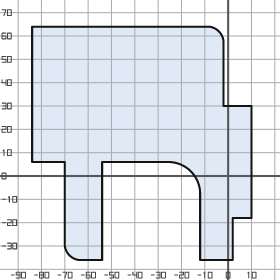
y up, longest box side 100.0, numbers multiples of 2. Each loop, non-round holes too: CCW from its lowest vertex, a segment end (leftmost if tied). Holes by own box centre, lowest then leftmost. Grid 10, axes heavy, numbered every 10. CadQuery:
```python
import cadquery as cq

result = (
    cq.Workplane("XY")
    .moveTo(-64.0, -36.0)
    .lineTo(-54.0, -36.0)
    .lineTo(-54.0, 6.0)
    .lineTo(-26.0, 6.0)
    .threePointArc((-16.0, 2.0), (-12.0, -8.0))
    .lineTo(-12.0, -36.0)
    .lineTo(2.0, -36.0)
    .lineTo(2.0, -18.0)
    .lineTo(10.0, -18.0)
    .lineTo(10.0, 30.0)
    .lineTo(-2.0, 30.0)
    .lineTo(-2.0, 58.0)
    .threePointArc((-4.0, 62.0), (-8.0, 64.0))
    .lineTo(-84.0, 64.0)
    .lineTo(-84.0, 6.0)
    .lineTo(-70.0, 6.0)
    .lineTo(-70.0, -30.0)
    .threePointArc((-68.0, -34.0), (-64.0, -36.0))
    .close()
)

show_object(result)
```